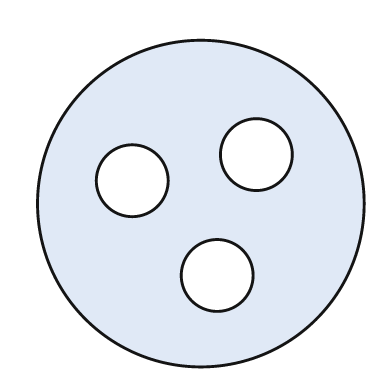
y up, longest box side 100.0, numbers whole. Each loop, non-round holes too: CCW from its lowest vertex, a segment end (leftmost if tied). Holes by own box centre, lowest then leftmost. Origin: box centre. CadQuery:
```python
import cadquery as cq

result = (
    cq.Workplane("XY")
    .moveTo(0.0, 0.0)
    .circle(50.0)
    .moveTo(5.0, -22.0)
    .circle(11.0)
    .moveTo(-21.0, 7.0)
    .circle(11.0)
    .moveTo(17.0, 15.0)
    .circle(11.0)
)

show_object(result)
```